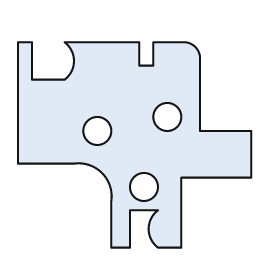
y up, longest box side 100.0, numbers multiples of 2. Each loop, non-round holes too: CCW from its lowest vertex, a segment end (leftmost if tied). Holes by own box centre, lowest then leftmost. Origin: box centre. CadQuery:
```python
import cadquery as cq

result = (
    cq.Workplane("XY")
    .moveTo(-10.0, -44.0)
    .lineTo(-2.0, -44.0)
    .lineTo(-2.0, -28.0)
    .lineTo(10.0, -28.0)
    .threePointArc((6.0, -36.0), (10.0, -44.0))
    .lineTo(20.0, -44.0)
    .lineTo(20.0, -14.0)
    .lineTo(50.0, -14.0)
    .lineTo(50.0, 6.0)
    .lineTo(28.0, 6.0)
    .lineTo(28.0, 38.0)
    .threePointArc((26.0, 42.0), (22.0, 44.0))
    .lineTo(8.0, 44.0)
    .lineTo(8.0, 34.0)
    .lineTo(2.0, 34.0)
    .lineTo(2.0, 44.0)
    .lineTo(-30.0, 44.0)
    .threePointArc((-26.0, 36.0), (-30.0, 28.0))
    .lineTo(-44.0, 28.0)
    .lineTo(-44.0, 44.0)
    .lineTo(-50.0, 44.0)
    .lineTo(-50.0, -8.0)
    .lineTo(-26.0, -8.0)
    .threePointArc((-14.0, -12.0), (-10.0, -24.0))
    .close()
    .moveTo(4.0, -18.0)
    .circle(6.0)
    .moveTo(-16.0, 6.0)
    .circle(6.0)
    .moveTo(14.0, 12.0)
    .circle(6.0)
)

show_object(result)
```